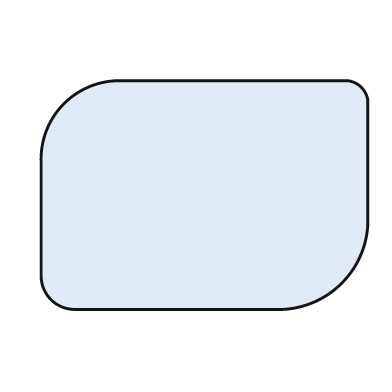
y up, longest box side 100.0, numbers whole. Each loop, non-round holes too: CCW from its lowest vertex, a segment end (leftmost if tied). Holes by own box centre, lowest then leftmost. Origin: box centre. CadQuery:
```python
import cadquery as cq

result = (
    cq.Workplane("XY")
    .moveTo(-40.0, -35.0)
    .lineTo(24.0, -35.0)
    .threePointArc((42.0, -27.0), (50.0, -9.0))
    .lineTo(50.0, 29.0)
    .threePointArc((48.0, 33.0), (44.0, 35.0))
    .lineTo(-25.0, 35.0)
    .threePointArc((-43.0, 28.0), (-50.0, 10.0))
    .lineTo(-50.0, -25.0)
    .threePointArc((-47.0, -32.0), (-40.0, -35.0))
    .close()
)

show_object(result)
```